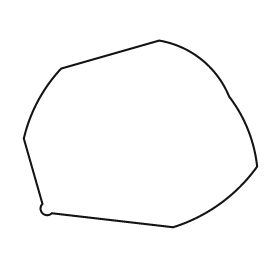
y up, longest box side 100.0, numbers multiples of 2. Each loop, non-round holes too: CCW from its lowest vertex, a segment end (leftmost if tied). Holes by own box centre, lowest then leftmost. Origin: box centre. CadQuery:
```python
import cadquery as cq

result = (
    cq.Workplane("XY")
    .moveTo(14.0, -40.0)
    .threePointArc((34.0, -30.0), (50.0, -14.0))
    .threePointArc((46.0, 2.0), (38.0, 16.0))
    .threePointArc((26.0, 32.0), (8.0, 40.0))
    .lineTo(-34.0, 28.0)
    .threePointArc((-44.0, 14.0), (-50.0, -2.0))
    .lineTo(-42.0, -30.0)
    .threePointArc((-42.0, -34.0), (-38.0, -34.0))
    .close()
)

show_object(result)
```